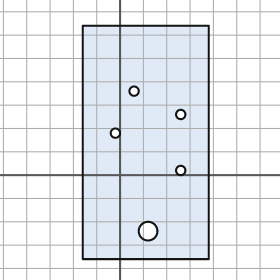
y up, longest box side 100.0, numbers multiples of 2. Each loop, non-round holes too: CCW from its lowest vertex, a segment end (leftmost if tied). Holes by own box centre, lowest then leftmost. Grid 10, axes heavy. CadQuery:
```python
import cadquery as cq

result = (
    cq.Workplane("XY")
    .moveTo(-16.0, -36.0)
    .lineTo(38.0, -36.0)
    .lineTo(38.0, 64.0)
    .lineTo(-16.0, 64.0)
    .close()
    .moveTo(12.0, -24.0)
    .circle(4.0)
    .moveTo(26.0, 2.0)
    .circle(2.0)
    .moveTo(-2.0, 18.0)
    .circle(2.0)
    .moveTo(26.0, 26.0)
    .circle(2.0)
    .moveTo(6.0, 36.0)
    .circle(2.0)
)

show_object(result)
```